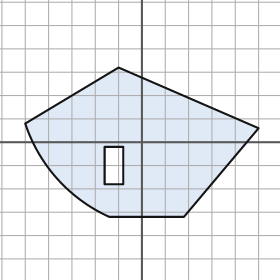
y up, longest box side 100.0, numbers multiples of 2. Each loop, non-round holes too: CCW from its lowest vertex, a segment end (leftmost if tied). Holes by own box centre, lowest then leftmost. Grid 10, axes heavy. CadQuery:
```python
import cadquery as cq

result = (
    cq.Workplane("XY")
    .moveTo(-14.0, -32.0)
    .lineTo(18.0, -32.0)
    .lineTo(50.0, 6.0)
    .lineTo(-10.0, 32.0)
    .lineTo(-50.0, 8.0)
    .threePointArc((-36.0, -16.0), (-14.0, -32.0))
    .close()
    .moveTo(-16.0, -18.0)
    .lineTo(-8.0, -18.0)
    .lineTo(-8.0, -2.0)
    .lineTo(-16.0, -2.0)
    .close()
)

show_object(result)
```